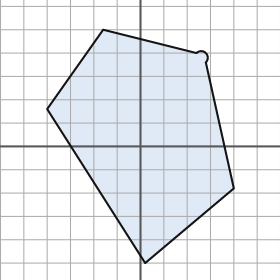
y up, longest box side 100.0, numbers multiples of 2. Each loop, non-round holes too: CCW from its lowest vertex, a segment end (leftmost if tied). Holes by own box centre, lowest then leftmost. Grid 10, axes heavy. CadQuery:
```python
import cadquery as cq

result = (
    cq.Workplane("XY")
    .moveTo(2.0, -50.0)
    .lineTo(40.0, -18.0)
    .lineTo(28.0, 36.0)
    .threePointArc((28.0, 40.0), (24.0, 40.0))
    .lineTo(-16.0, 50.0)
    .lineTo(-40.0, 16.0)
    .close()
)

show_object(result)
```